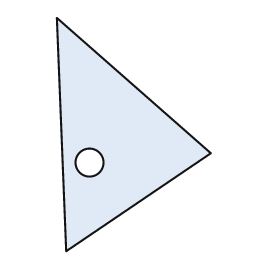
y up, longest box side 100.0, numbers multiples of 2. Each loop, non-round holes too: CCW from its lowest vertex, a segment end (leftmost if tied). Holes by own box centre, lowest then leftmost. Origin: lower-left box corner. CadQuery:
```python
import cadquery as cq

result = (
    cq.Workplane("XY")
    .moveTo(4.0, 0.0)
    .lineTo(66.0, 42.0)
    .lineTo(0.0, 100.0)
    .close()
    .moveTo(14.0, 38.0)
    .circle(6.0)
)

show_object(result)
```